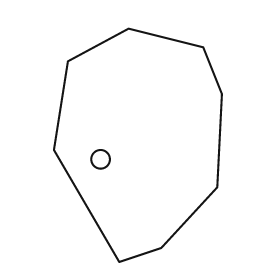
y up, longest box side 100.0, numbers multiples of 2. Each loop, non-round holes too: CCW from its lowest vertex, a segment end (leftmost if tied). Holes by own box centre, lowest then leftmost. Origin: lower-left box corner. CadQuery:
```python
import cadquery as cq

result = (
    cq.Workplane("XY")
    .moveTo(28.0, 0.0)
    .lineTo(46.0, 6.0)
    .lineTo(70.0, 32.0)
    .lineTo(72.0, 72.0)
    .lineTo(64.0, 92.0)
    .lineTo(32.0, 100.0)
    .lineTo(6.0, 86.0)
    .lineTo(0.0, 48.0)
    .close()
    .moveTo(20.0, 44.0)
    .circle(4.0)
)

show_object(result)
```